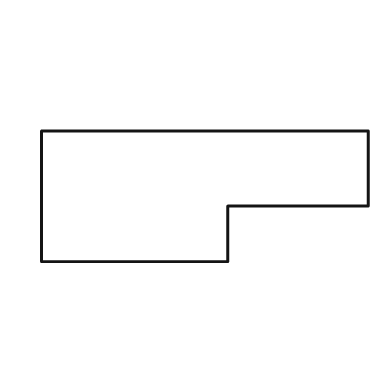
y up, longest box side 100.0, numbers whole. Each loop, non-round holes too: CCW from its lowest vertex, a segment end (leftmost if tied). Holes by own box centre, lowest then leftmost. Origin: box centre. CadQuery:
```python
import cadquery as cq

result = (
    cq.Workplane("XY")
    .moveTo(-50.0, -20.0)
    .lineTo(7.0, -20.0)
    .lineTo(7.0, -3.0)
    .lineTo(50.0, -3.0)
    .lineTo(50.0, 20.0)
    .lineTo(-50.0, 20.0)
    .close()
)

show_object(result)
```